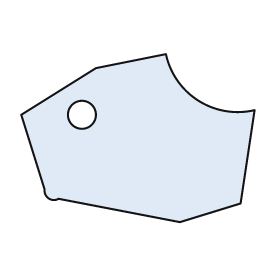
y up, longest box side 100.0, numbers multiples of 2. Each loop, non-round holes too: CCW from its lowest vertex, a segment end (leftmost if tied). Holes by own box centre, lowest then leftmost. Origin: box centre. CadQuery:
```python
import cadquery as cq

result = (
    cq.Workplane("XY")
    .moveTo(18.0, -36.0)
    .lineTo(44.0, -28.0)
    .lineTo(50.0, 12.0)
    .threePointArc((26.0, 16.0), (12.0, 36.0))
    .lineTo(-18.0, 30.0)
    .lineTo(-50.0, 10.0)
    .lineTo(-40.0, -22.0)
    .threePointArc((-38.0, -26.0), (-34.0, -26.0))
    .close()
    .moveTo(-24.0, 10.0)
    .circle(6.0)
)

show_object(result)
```